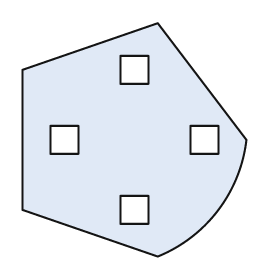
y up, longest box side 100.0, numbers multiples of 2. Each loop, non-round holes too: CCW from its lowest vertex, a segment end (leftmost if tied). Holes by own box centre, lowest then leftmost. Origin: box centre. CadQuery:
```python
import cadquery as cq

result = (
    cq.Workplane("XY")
    .moveTo(10.0, -50.0)
    .threePointArc((36.0, -30.0), (48.0, 0.0))
    .lineTo(10.0, 50.0)
    .lineTo(-48.0, 30.0)
    .lineTo(-48.0, -30.0)
    .close()
    .moveTo(-6.0, -36.0)
    .lineTo(6.0, -36.0)
    .lineTo(6.0, -24.0)
    .lineTo(-6.0, -24.0)
    .close()
    .moveTo(-36.0, -6.0)
    .lineTo(-24.0, -6.0)
    .lineTo(-24.0, 6.0)
    .lineTo(-36.0, 6.0)
    .close()
    .moveTo(24.0, -6.0)
    .lineTo(36.0, -6.0)
    .lineTo(36.0, 6.0)
    .lineTo(24.0, 6.0)
    .close()
    .moveTo(-6.0, 24.0)
    .lineTo(6.0, 24.0)
    .lineTo(6.0, 36.0)
    .lineTo(-6.0, 36.0)
    .close()
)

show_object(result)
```